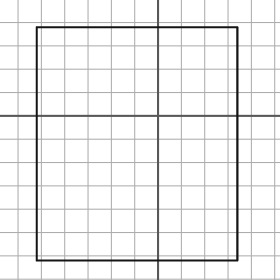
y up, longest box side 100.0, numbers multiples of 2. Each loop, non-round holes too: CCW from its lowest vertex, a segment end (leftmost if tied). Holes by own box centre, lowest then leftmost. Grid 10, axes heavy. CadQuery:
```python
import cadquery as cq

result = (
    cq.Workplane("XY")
    .moveTo(-52.0, -62.0)
    .lineTo(34.0, -62.0)
    .lineTo(34.0, 38.0)
    .lineTo(-52.0, 38.0)
    .close()
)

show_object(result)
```